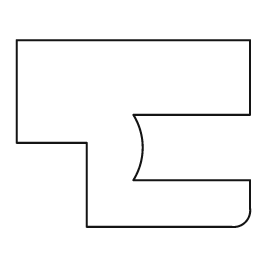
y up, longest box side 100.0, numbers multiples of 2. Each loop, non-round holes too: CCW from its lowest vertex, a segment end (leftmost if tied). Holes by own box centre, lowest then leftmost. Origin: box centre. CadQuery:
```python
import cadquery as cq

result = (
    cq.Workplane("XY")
    .moveTo(-20.0, -40.0)
    .lineTo(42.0, -40.0)
    .threePointArc((48.0, -38.0), (50.0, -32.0))
    .lineTo(50.0, -20.0)
    .lineTo(0.0, -20.0)
    .threePointArc((4.0, -6.0), (0.0, 8.0))
    .lineTo(50.0, 8.0)
    .lineTo(50.0, 40.0)
    .lineTo(-50.0, 40.0)
    .lineTo(-50.0, -4.0)
    .lineTo(-20.0, -4.0)
    .close()
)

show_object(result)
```